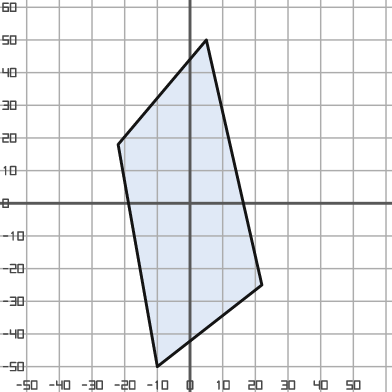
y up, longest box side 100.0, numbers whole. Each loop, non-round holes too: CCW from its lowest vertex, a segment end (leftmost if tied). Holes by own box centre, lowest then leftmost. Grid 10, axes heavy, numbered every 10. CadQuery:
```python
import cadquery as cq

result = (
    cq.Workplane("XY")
    .moveTo(-10.0, -50.0)
    .lineTo(22.0, -25.0)
    .lineTo(5.0, 50.0)
    .lineTo(-22.0, 18.0)
    .close()
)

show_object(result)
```